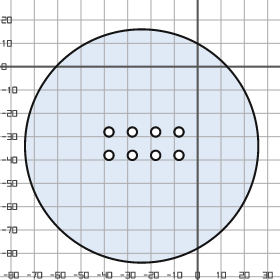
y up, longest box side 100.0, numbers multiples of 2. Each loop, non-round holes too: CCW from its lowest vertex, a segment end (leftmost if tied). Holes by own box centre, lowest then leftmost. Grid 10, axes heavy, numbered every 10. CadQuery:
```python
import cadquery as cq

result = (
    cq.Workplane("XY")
    .moveTo(-24.0, -34.0)
    .circle(50.0)
    .moveTo(-38.0, -38.0)
    .circle(2.0)
    .moveTo(-28.0, -38.0)
    .circle(2.0)
    .moveTo(-18.0, -38.0)
    .circle(2.0)
    .moveTo(-8.0, -38.0)
    .circle(2.0)
    .moveTo(-38.0, -28.0)
    .circle(2.0)
    .moveTo(-28.0, -28.0)
    .circle(2.0)
    .moveTo(-18.0, -28.0)
    .circle(2.0)
    .moveTo(-8.0, -28.0)
    .circle(2.0)
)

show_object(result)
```